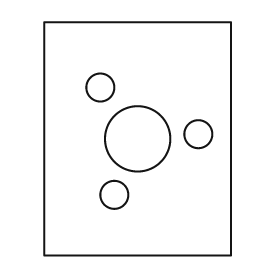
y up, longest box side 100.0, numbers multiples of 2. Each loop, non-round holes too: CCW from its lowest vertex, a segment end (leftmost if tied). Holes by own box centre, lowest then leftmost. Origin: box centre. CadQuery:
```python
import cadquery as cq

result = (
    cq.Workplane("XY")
    .moveTo(-40.0, -50.0)
    .lineTo(40.0, -50.0)
    .lineTo(40.0, 50.0)
    .lineTo(-40.0, 50.0)
    .close()
    .moveTo(-10.0, -24.0)
    .circle(6.0)
    .moveTo(0.0, 0.0)
    .circle(14.0)
    .moveTo(26.0, 2.0)
    .circle(6.0)
    .moveTo(-16.0, 22.0)
    .circle(6.0)
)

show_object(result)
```